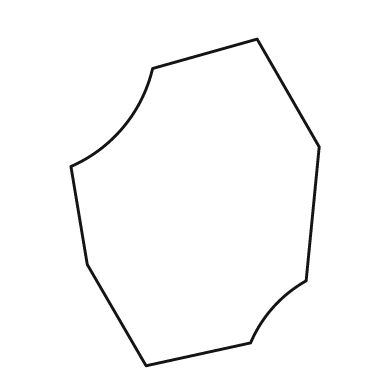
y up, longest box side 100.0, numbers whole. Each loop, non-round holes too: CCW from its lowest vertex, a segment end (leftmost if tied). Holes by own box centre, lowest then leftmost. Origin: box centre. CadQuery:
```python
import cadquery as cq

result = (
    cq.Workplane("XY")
    .moveTo(-15.0, -50.0)
    .lineTo(17.0, -43.0)
    .threePointArc((24.0, -32.0), (34.0, -24.0))
    .lineTo(38.0, 17.0)
    .lineTo(19.0, 50.0)
    .lineTo(-13.0, 41.0)
    .threePointArc((-22.0, 23.0), (-38.0, 11.0))
    .lineTo(-33.0, -19.0)
    .close()
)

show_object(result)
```